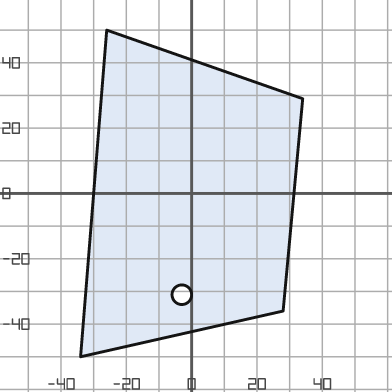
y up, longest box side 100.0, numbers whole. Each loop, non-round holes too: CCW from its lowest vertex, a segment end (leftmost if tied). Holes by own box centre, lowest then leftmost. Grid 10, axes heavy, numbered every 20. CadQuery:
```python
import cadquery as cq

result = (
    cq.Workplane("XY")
    .moveTo(-34.0, -50.0)
    .lineTo(28.0, -36.0)
    .lineTo(34.0, 29.0)
    .lineTo(-26.0, 50.0)
    .close()
    .moveTo(-3.0, -31.0)
    .circle(3.0)
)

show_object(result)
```